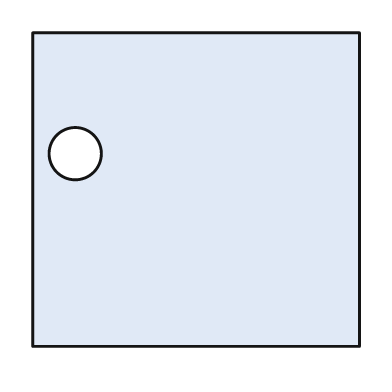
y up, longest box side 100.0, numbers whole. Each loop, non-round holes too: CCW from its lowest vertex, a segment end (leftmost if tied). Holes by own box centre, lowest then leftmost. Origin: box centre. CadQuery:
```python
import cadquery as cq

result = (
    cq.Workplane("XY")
    .moveTo(-50.0, -48.0)
    .lineTo(50.0, -48.0)
    .lineTo(50.0, 48.0)
    .lineTo(-50.0, 48.0)
    .close()
    .moveTo(-37.0, 11.0)
    .circle(8.0)
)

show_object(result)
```